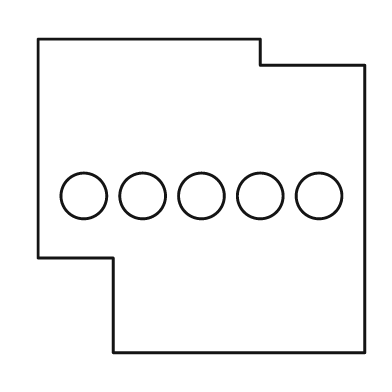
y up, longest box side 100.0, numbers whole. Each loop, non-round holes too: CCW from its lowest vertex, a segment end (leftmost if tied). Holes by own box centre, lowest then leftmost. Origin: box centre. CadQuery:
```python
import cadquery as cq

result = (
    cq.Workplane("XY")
    .moveTo(-27.0, -48.0)
    .lineTo(50.0, -48.0)
    .lineTo(50.0, 40.0)
    .lineTo(18.0, 40.0)
    .lineTo(18.0, 48.0)
    .lineTo(-50.0, 48.0)
    .lineTo(-50.0, -19.0)
    .lineTo(-27.0, -19.0)
    .close()
    .moveTo(-36.0, 0.0)
    .circle(7.0)
    .moveTo(-18.0, 0.0)
    .circle(7.0)
    .moveTo(0.0, 0.0)
    .circle(7.0)
    .moveTo(18.0, 0.0)
    .circle(7.0)
    .moveTo(36.0, 0.0)
    .circle(7.0)
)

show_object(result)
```